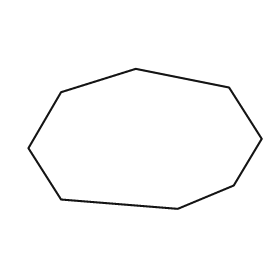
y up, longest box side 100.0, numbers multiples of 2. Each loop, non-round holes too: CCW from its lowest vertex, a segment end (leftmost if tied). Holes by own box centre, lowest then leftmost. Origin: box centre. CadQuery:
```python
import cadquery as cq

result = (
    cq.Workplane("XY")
    .moveTo(14.0, -30.0)
    .lineTo(38.0, -20.0)
    .lineTo(50.0, 0.0)
    .lineTo(36.0, 22.0)
    .lineTo(-4.0, 30.0)
    .lineTo(-36.0, 20.0)
    .lineTo(-50.0, -4.0)
    .lineTo(-36.0, -26.0)
    .close()
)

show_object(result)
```